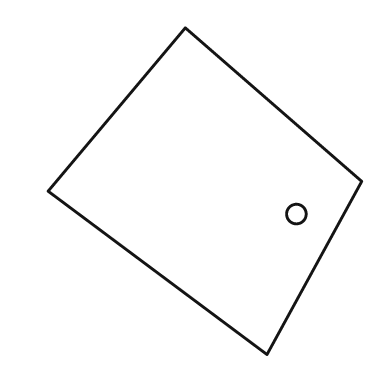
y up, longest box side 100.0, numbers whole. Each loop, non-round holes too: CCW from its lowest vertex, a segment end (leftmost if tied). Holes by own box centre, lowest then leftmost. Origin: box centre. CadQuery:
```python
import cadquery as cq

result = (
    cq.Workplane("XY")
    .moveTo(19.0, -50.0)
    .lineTo(48.0, 3.0)
    .lineTo(-6.0, 50.0)
    .lineTo(-48.0, 0.0)
    .close()
    .moveTo(28.0, -7.0)
    .circle(3.0)
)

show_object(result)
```